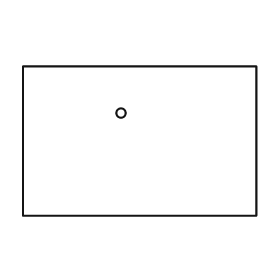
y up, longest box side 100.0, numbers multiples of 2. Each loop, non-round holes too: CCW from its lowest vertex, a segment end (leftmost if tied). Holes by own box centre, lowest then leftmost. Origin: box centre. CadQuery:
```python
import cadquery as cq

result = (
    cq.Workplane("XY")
    .moveTo(-50.0, -32.0)
    .lineTo(50.0, -32.0)
    .lineTo(50.0, 32.0)
    .lineTo(-50.0, 32.0)
    .close()
    .moveTo(-8.0, 12.0)
    .circle(2.0)
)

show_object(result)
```